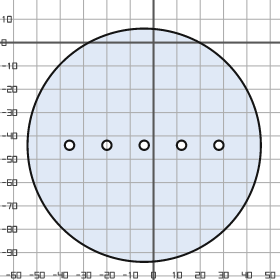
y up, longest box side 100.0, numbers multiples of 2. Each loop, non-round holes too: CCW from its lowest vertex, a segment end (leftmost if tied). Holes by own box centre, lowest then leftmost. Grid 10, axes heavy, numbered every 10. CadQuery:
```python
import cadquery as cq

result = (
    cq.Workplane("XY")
    .moveTo(-4.0, -44.0)
    .circle(50.0)
    .moveTo(-36.0, -44.0)
    .circle(2.0)
    .moveTo(-20.0, -44.0)
    .circle(2.0)
    .moveTo(-4.0, -44.0)
    .circle(2.0)
    .moveTo(12.0, -44.0)
    .circle(2.0)
    .moveTo(28.0, -44.0)
    .circle(2.0)
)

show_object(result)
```